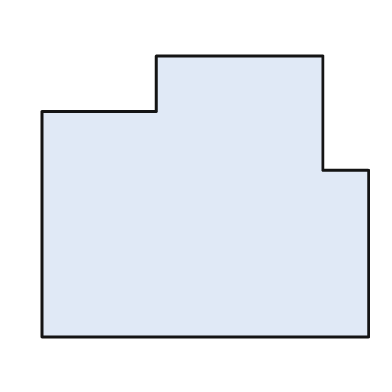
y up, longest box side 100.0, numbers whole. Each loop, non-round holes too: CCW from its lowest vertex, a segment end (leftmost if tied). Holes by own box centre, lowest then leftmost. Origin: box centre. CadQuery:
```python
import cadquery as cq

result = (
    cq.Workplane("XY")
    .moveTo(-50.0, -43.0)
    .lineTo(50.0, -43.0)
    .lineTo(50.0, 8.0)
    .lineTo(36.0, 8.0)
    .lineTo(36.0, 43.0)
    .lineTo(-15.0, 43.0)
    .lineTo(-15.0, 26.0)
    .lineTo(-50.0, 26.0)
    .close()
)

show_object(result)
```